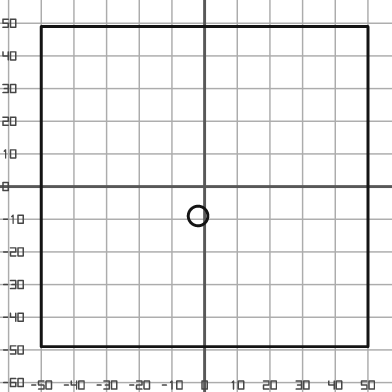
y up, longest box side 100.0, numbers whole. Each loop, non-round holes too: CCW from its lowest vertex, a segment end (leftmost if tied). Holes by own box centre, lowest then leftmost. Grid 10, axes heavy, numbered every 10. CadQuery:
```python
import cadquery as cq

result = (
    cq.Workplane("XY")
    .moveTo(-50.0, -49.0)
    .lineTo(50.0, -49.0)
    .lineTo(50.0, 49.0)
    .lineTo(-50.0, 49.0)
    .close()
    .moveTo(-2.0, -9.0)
    .circle(3.0)
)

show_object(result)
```